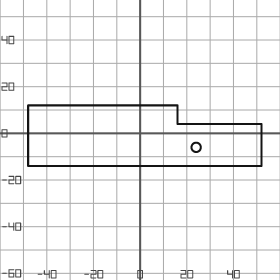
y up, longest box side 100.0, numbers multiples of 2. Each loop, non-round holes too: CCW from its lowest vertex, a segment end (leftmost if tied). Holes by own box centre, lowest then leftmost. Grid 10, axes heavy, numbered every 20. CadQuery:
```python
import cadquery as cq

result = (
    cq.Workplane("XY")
    .moveTo(-48.0, -14.0)
    .lineTo(52.0, -14.0)
    .lineTo(52.0, 4.0)
    .lineTo(16.0, 4.0)
    .lineTo(16.0, 12.0)
    .lineTo(-48.0, 12.0)
    .close()
    .moveTo(24.0, -6.0)
    .circle(2.0)
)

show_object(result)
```